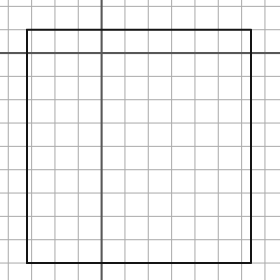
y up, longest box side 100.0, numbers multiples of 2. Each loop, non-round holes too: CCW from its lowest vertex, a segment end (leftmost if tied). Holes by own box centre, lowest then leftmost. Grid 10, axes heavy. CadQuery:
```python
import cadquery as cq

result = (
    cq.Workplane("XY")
    .moveTo(-32.0, -90.0)
    .lineTo(64.0, -90.0)
    .lineTo(64.0, 10.0)
    .lineTo(-32.0, 10.0)
    .close()
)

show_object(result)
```